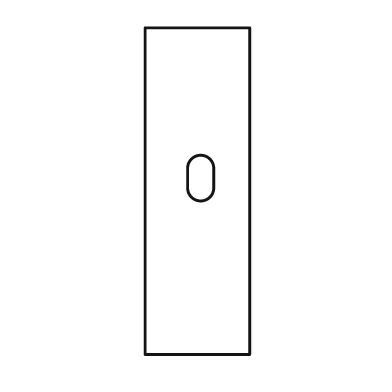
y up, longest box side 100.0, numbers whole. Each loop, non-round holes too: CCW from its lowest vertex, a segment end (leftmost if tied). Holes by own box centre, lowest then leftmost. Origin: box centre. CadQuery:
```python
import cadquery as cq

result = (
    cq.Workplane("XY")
    .moveTo(-16.0, -50.0)
    .lineTo(16.0, -50.0)
    .lineTo(16.0, 50.0)
    .lineTo(-16.0, 50.0)
    .close()
    .moveTo(-3.0, 1.0)
    .threePointArc((1.0, -3.0), (5.0, 1.0))
    .lineTo(5.0, 7.0)
    .threePointArc((1.0, 11.0), (-3.0, 7.0))
    .close()
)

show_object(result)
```